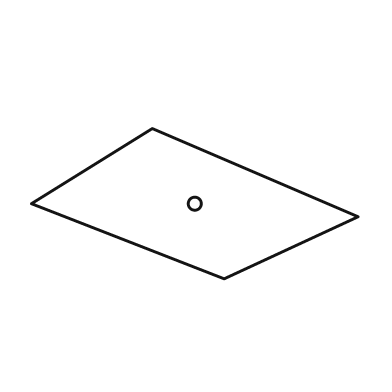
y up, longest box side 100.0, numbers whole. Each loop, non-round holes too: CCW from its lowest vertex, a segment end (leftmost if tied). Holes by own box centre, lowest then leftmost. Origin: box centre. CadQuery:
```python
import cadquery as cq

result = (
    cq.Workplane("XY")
    .moveTo(9.0, -23.0)
    .lineTo(50.0, -4.0)
    .lineTo(-13.0, 23.0)
    .lineTo(-50.0, 0.0)
    .close()
    .moveTo(0.0, 0.0)
    .circle(2.0)
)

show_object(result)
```